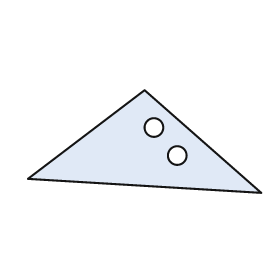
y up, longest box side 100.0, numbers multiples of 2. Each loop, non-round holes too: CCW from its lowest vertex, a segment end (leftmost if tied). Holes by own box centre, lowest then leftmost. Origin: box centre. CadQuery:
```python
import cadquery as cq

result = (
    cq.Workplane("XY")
    .moveTo(50.0, -22.0)
    .lineTo(0.0, 22.0)
    .lineTo(-50.0, -16.0)
    .close()
    .moveTo(14.0, -6.0)
    .circle(4.0)
    .moveTo(4.0, 6.0)
    .circle(4.0)
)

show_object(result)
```